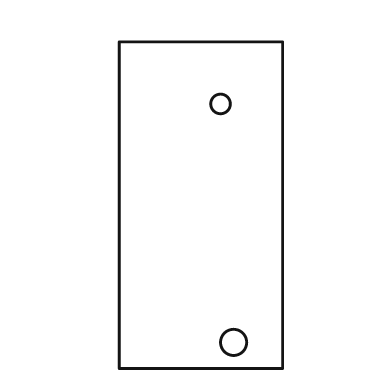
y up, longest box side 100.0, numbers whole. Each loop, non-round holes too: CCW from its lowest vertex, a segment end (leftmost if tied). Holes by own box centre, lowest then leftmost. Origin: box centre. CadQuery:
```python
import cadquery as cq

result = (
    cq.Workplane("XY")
    .moveTo(-25.0, -50.0)
    .lineTo(25.0, -50.0)
    .lineTo(25.0, 50.0)
    .lineTo(-25.0, 50.0)
    .close()
    .moveTo(10.0, -42.0)
    .circle(4.0)
    .moveTo(6.0, 31.0)
    .circle(3.0)
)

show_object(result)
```